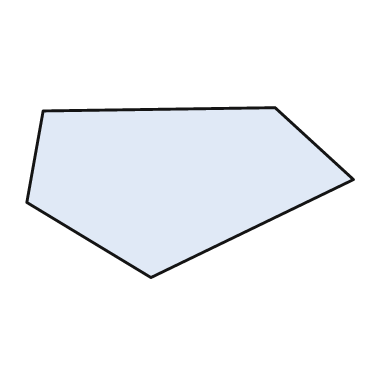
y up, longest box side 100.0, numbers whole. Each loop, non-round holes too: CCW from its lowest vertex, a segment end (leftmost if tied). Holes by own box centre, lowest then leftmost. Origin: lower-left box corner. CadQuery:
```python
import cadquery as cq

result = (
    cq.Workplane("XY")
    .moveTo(38.0, 0.0)
    .lineTo(100.0, 30.0)
    .lineTo(76.0, 52.0)
    .lineTo(5.0, 51.0)
    .lineTo(0.0, 23.0)
    .close()
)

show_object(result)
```